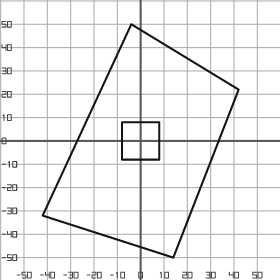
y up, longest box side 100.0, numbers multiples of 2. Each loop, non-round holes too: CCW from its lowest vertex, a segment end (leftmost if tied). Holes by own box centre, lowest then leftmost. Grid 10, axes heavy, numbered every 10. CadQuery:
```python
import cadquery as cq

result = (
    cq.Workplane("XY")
    .moveTo(14.0, -50.0)
    .lineTo(42.0, 22.0)
    .lineTo(-4.0, 50.0)
    .lineTo(-42.0, -32.0)
    .close()
    .moveTo(-8.0, -8.0)
    .lineTo(8.0, -8.0)
    .lineTo(8.0, 8.0)
    .lineTo(-8.0, 8.0)
    .close()
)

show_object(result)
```